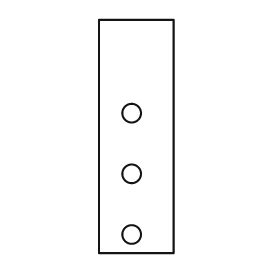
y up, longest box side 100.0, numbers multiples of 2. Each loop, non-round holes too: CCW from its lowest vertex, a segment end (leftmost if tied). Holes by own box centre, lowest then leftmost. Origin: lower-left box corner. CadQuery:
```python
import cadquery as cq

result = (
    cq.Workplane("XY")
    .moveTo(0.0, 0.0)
    .lineTo(32.0, 0.0)
    .lineTo(32.0, 100.0)
    .lineTo(0.0, 100.0)
    .close()
    .moveTo(14.0, 8.0)
    .circle(4.0)
    .moveTo(14.0, 34.0)
    .circle(4.0)
    .moveTo(14.0, 60.0)
    .circle(4.0)
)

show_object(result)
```